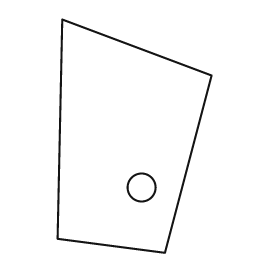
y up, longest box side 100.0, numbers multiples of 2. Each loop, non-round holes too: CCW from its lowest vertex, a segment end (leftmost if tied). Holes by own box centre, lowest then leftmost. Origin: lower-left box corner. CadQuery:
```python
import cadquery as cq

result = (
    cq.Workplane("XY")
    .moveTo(46.0, 0.0)
    .lineTo(66.0, 76.0)
    .lineTo(2.0, 100.0)
    .lineTo(0.0, 6.0)
    .close()
    .moveTo(36.0, 28.0)
    .circle(6.0)
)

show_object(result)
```